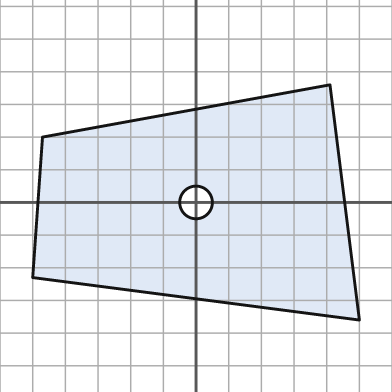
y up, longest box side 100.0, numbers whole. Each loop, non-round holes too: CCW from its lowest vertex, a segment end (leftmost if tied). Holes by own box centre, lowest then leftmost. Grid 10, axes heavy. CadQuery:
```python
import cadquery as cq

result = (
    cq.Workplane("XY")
    .moveTo(50.0, -36.0)
    .lineTo(41.0, 36.0)
    .lineTo(-47.0, 20.0)
    .lineTo(-50.0, -23.0)
    .close()
    .moveTo(0.0, 0.0)
    .circle(5.0)
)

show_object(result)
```